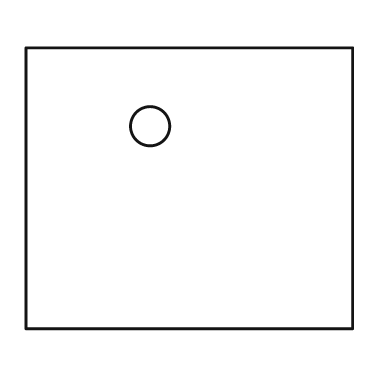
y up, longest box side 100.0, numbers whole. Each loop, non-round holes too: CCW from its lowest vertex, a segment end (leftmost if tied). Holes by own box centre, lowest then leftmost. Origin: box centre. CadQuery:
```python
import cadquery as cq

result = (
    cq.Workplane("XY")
    .moveTo(-50.0, -43.0)
    .lineTo(50.0, -43.0)
    .lineTo(50.0, 43.0)
    .lineTo(-50.0, 43.0)
    .close()
    .moveTo(-12.0, 19.0)
    .circle(6.0)
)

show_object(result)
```